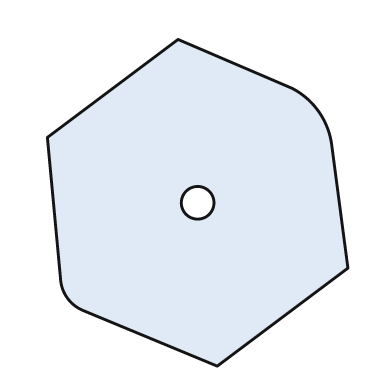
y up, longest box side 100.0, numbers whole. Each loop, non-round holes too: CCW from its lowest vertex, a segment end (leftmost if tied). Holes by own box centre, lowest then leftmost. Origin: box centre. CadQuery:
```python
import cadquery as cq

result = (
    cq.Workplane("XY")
    .moveTo(6.0, -50.0)
    .lineTo(46.0, -20.0)
    .lineTo(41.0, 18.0)
    .threePointArc((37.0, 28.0), (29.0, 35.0))
    .lineTo(-6.0, 50.0)
    .lineTo(-46.0, 20.0)
    .lineTo(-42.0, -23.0)
    .threePointArc((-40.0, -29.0), (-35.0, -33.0))
    .close()
    .moveTo(0.0, 0.0)
    .circle(5.0)
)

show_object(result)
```